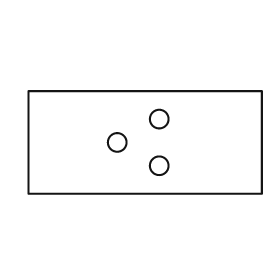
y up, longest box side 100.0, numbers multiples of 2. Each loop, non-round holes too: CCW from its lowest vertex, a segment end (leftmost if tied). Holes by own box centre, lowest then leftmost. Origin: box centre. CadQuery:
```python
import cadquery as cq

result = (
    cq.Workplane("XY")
    .moveTo(-50.0, -22.0)
    .lineTo(50.0, -22.0)
    .lineTo(50.0, 22.0)
    .lineTo(-50.0, 22.0)
    .close()
    .moveTo(6.0, -10.0)
    .circle(4.0)
    .moveTo(-12.0, 0.0)
    .circle(4.0)
    .moveTo(6.0, 10.0)
    .circle(4.0)
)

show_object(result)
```